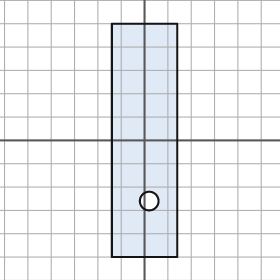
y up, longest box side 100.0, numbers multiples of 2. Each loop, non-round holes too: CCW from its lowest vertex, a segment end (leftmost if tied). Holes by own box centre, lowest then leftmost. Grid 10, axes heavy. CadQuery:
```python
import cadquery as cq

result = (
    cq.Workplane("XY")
    .moveTo(-14.0, -50.0)
    .lineTo(14.0, -50.0)
    .lineTo(14.0, 50.0)
    .lineTo(-14.0, 50.0)
    .close()
    .moveTo(2.0, -26.0)
    .circle(4.0)
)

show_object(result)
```